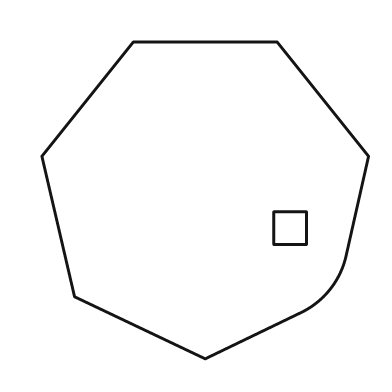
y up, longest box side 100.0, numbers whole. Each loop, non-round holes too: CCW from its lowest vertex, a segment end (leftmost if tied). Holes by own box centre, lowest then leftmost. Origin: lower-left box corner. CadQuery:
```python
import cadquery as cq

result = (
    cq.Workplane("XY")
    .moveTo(50.0, 0.0)
    .lineTo(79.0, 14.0)
    .threePointArc((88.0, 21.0), (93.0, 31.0))
    .lineTo(100.0, 62.0)
    .lineTo(72.0, 97.0)
    .lineTo(28.0, 97.0)
    .lineTo(0.0, 62.0)
    .lineTo(10.0, 19.0)
    .close()
    .moveTo(71.0, 35.0)
    .lineTo(81.0, 35.0)
    .lineTo(81.0, 45.0)
    .lineTo(71.0, 45.0)
    .close()
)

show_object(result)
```